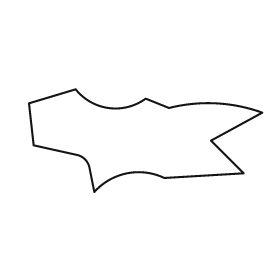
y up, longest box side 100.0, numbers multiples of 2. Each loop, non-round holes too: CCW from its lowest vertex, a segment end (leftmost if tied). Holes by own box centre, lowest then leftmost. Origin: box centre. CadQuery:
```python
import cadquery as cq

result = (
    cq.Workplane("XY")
    .moveTo(-22.0, -22.0)
    .threePointArc((-8.0, -14.0), (8.0, -16.0))
    .lineTo(42.0, -14.0)
    .lineTo(28.0, 0.0)
    .lineTo(50.0, 12.0)
    .threePointArc((30.0, 16.0), (10.0, 14.0))
    .lineTo(0.0, 18.0)
    .threePointArc((-16.0, 14.0), (-30.0, 22.0))
    .lineTo(-50.0, 16.0)
    .lineTo(-48.0, -2.0)
    .lineTo(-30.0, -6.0)
    .threePointArc((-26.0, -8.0), (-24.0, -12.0))
    .close()
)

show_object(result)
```